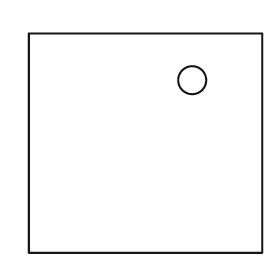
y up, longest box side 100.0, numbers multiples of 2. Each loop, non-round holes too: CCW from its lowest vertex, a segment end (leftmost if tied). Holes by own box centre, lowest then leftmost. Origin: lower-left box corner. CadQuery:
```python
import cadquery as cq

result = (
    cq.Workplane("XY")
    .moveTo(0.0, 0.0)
    .lineTo(100.0, 0.0)
    .lineTo(100.0, 94.0)
    .lineTo(0.0, 94.0)
    .close()
    .moveTo(70.0, 74.0)
    .circle(6.0)
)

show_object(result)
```